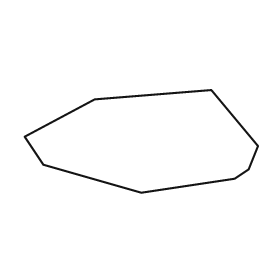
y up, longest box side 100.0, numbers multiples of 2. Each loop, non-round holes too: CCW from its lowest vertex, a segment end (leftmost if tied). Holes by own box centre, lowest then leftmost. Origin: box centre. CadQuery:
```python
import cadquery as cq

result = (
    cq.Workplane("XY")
    .moveTo(0.0, -22.0)
    .lineTo(40.0, -16.0)
    .lineTo(46.0, -12.0)
    .lineTo(50.0, -2.0)
    .lineTo(30.0, 22.0)
    .lineTo(-20.0, 18.0)
    .lineTo(-50.0, 2.0)
    .lineTo(-42.0, -10.0)
    .close()
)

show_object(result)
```